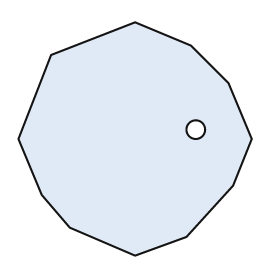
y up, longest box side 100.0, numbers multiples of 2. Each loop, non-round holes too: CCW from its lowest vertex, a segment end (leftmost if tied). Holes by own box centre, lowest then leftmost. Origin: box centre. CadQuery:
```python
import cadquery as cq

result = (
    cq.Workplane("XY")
    .moveTo(0.0, -50.0)
    .lineTo(22.0, -42.0)
    .lineTo(42.0, -20.0)
    .lineTo(50.0, 0.0)
    .lineTo(40.0, 24.0)
    .lineTo(24.0, 40.0)
    .lineTo(0.0, 50.0)
    .lineTo(-36.0, 36.0)
    .lineTo(-50.0, 0.0)
    .lineTo(-40.0, -24.0)
    .lineTo(-28.0, -38.0)
    .close()
    .moveTo(26.0, 4.0)
    .circle(4.0)
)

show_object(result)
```